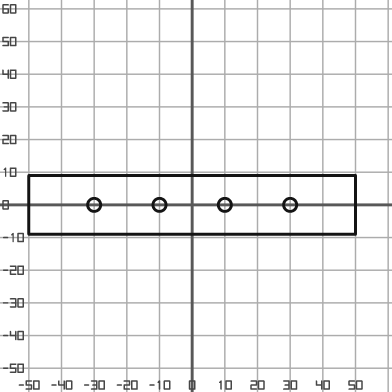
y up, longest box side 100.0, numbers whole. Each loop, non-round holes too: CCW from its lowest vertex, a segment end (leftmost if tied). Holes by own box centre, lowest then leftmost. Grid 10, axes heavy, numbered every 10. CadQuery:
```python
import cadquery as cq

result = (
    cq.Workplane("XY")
    .moveTo(-50.0, -9.0)
    .lineTo(50.0, -9.0)
    .lineTo(50.0, 9.0)
    .lineTo(-50.0, 9.0)
    .close()
    .moveTo(-30.0, 0.0)
    .circle(2.0)
    .moveTo(-10.0, 0.0)
    .circle(2.0)
    .moveTo(10.0, 0.0)
    .circle(2.0)
    .moveTo(30.0, 0.0)
    .circle(2.0)
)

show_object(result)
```